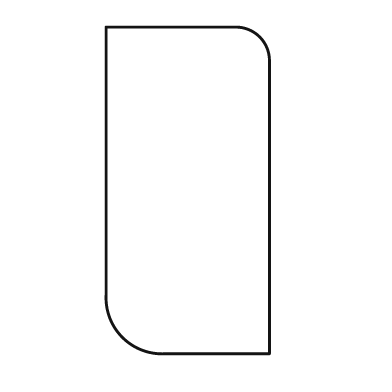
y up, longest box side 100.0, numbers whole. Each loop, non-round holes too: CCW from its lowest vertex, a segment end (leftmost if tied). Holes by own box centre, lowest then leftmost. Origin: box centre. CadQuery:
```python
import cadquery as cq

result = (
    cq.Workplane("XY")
    .moveTo(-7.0, -50.0)
    .lineTo(25.0, -50.0)
    .lineTo(25.0, 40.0)
    .threePointArc((22.0, 47.0), (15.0, 50.0))
    .lineTo(-25.0, 50.0)
    .lineTo(-25.0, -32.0)
    .threePointArc((-20.0, -45.0), (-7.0, -50.0))
    .close()
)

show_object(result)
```